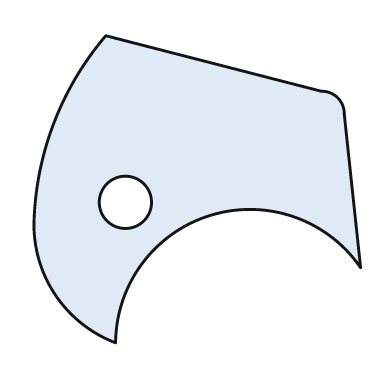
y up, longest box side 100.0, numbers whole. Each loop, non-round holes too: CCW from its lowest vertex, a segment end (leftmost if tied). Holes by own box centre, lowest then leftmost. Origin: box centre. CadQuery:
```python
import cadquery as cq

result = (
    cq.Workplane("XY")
    .moveTo(-25.0, -47.0)
    .threePointArc((4.0, -8.0), (50.0, -24.0))
    .lineTo(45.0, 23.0)
    .threePointArc((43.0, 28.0), (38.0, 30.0))
    .lineTo(-28.0, 47.0)
    .threePointArc((-44.0, 20.0), (-50.0, -11.0))
    .threePointArc((-43.0, -33.0), (-25.0, -47.0))
    .close()
    .moveTo(-22.0, -4.0)
    .circle(8.0)
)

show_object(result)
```